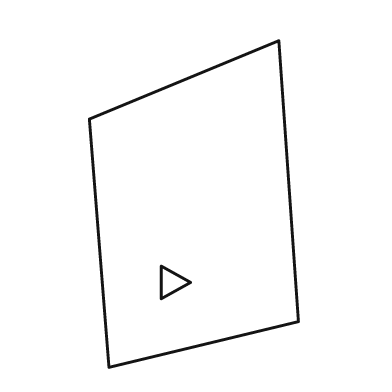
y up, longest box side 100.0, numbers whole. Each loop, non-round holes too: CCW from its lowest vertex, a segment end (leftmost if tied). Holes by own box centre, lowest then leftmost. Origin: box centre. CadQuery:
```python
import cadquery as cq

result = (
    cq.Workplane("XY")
    .moveTo(-26.0, -50.0)
    .lineTo(32.0, -36.0)
    .lineTo(26.0, 50.0)
    .lineTo(-32.0, 26.0)
    .close()
    .moveTo(-10.0, -29.0)
    .lineTo(-1.0, -24.0)
    .lineTo(-10.0, -19.0)
    .close()
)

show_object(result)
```